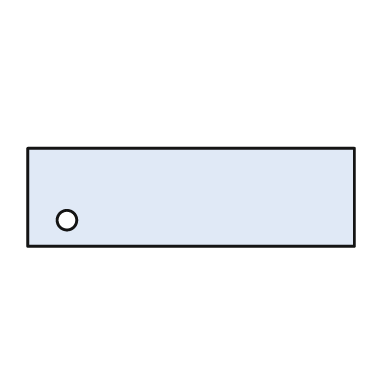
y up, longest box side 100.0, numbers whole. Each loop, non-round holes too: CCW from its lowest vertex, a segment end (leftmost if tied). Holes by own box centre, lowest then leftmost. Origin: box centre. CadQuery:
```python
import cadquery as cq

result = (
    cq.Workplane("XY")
    .moveTo(-50.0, -15.0)
    .lineTo(50.0, -15.0)
    .lineTo(50.0, 15.0)
    .lineTo(-50.0, 15.0)
    .close()
    .moveTo(-38.0, -7.0)
    .circle(3.0)
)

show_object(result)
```